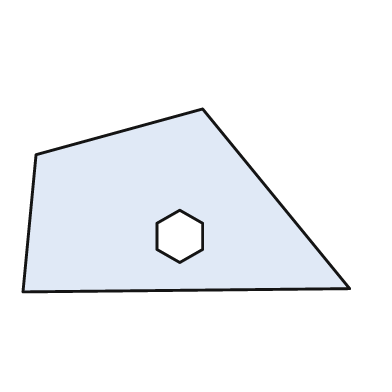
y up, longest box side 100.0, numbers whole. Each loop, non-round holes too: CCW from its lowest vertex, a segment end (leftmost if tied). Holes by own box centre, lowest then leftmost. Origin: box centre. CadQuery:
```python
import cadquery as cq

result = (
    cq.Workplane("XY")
    .moveTo(-50.0, -28.0)
    .lineTo(50.0, -27.0)
    .lineTo(5.0, 28.0)
    .lineTo(-46.0, 14.0)
    .close()
    .moveTo(-2.0, -19.0)
    .lineTo(5.0, -15.0)
    .lineTo(5.0, -7.0)
    .lineTo(-2.0, -3.0)
    .lineTo(-9.0, -7.0)
    .lineTo(-9.0, -15.0)
    .close()
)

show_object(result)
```